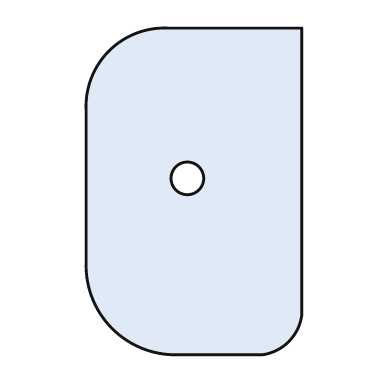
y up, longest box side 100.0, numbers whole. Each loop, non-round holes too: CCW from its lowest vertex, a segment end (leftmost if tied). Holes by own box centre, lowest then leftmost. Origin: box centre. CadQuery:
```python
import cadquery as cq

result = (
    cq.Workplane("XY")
    .moveTo(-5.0, -50.0)
    .lineTo(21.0, -50.0)
    .threePointArc((29.0, -46.0), (33.0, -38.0))
    .lineTo(33.0, 50.0)
    .lineTo(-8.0, 50.0)
    .threePointArc((-26.0, 43.0), (-33.0, 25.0))
    .lineTo(-33.0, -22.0)
    .threePointArc((-25.0, -42.0), (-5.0, -50.0))
    .close()
    .moveTo(-2.0, 4.0)
    .circle(5.0)
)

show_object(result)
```